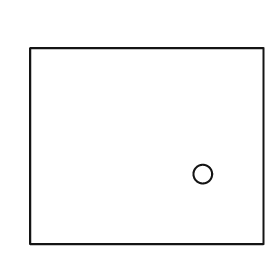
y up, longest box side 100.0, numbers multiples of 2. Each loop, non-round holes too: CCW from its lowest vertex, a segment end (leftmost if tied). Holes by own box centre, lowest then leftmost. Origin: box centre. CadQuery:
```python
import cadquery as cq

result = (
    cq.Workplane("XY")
    .moveTo(-50.0, -42.0)
    .lineTo(50.0, -42.0)
    .lineTo(50.0, 42.0)
    .lineTo(-50.0, 42.0)
    .close()
    .moveTo(24.0, -12.0)
    .circle(4.0)
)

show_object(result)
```